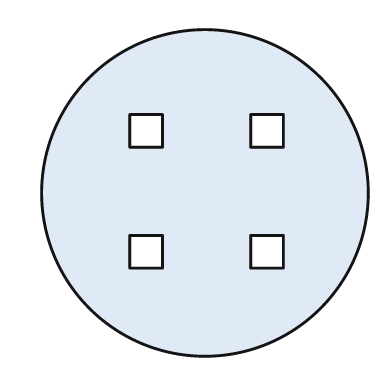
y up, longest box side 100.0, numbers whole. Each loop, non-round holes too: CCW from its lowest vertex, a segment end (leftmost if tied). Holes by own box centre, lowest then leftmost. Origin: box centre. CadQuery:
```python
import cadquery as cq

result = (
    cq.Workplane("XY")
    .moveTo(0.0, 0.0)
    .circle(50.0)
    .moveTo(-23.0, -23.0)
    .lineTo(-13.0, -23.0)
    .lineTo(-13.0, -13.0)
    .lineTo(-23.0, -13.0)
    .close()
    .moveTo(14.0, -23.0)
    .lineTo(24.0, -23.0)
    .lineTo(24.0, -13.0)
    .lineTo(14.0, -13.0)
    .close()
    .moveTo(-23.0, 14.0)
    .lineTo(-13.0, 14.0)
    .lineTo(-13.0, 24.0)
    .lineTo(-23.0, 24.0)
    .close()
    .moveTo(14.0, 14.0)
    .lineTo(24.0, 14.0)
    .lineTo(24.0, 24.0)
    .lineTo(14.0, 24.0)
    .close()
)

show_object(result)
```